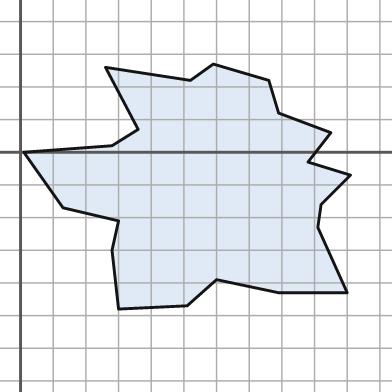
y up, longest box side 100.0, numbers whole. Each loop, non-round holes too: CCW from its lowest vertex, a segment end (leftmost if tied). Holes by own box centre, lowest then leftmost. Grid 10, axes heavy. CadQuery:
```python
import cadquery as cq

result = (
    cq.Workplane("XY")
    .moveTo(30.0, -48.0)
    .lineTo(51.0, -47.0)
    .lineTo(60.0, -39.0)
    .lineTo(79.0, -43.0)
    .lineTo(100.0, -43.0)
    .lineTo(91.0, -23.0)
    .lineTo(92.0, -16.0)
    .lineTo(101.0, -7.0)
    .lineTo(88.0, -3.0)
    .lineTo(95.0, 6.0)
    .lineTo(79.0, 12.0)
    .lineTo(76.0, 22.0)
    .lineTo(59.0, 27.0)
    .lineTo(52.0, 22.0)
    .lineTo(26.0, 26.0)
    .lineTo(36.0, 7.0)
    .lineTo(28.0, 2.0)
    .lineTo(1.0, 0.0)
    .lineTo(13.0, -17.0)
    .lineTo(30.0, -21.0)
    .lineTo(28.0, -30.0)
    .close()
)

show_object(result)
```